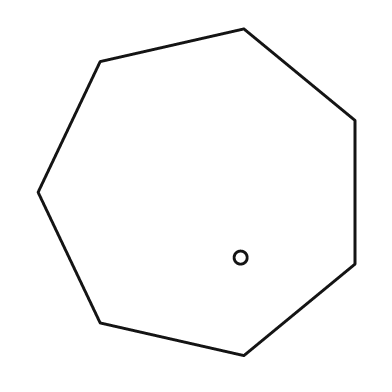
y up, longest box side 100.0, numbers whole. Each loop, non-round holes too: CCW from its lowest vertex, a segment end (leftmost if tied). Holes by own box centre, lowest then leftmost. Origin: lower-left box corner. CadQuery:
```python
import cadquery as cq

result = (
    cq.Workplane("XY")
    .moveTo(63.0, 0.0)
    .lineTo(97.0, 28.0)
    .lineTo(97.0, 72.0)
    .lineTo(63.0, 100.0)
    .lineTo(19.0, 90.0)
    .lineTo(0.0, 50.0)
    .lineTo(19.0, 10.0)
    .close()
    .moveTo(62.0, 30.0)
    .circle(2.0)
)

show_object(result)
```